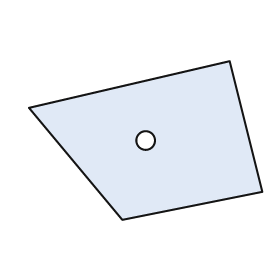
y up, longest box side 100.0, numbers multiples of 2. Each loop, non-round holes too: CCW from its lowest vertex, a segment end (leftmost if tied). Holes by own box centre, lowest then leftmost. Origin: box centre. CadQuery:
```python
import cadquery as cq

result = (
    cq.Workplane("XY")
    .moveTo(-10.0, -34.0)
    .lineTo(50.0, -22.0)
    .lineTo(36.0, 34.0)
    .lineTo(-50.0, 14.0)
    .close()
    .moveTo(0.0, 0.0)
    .circle(4.0)
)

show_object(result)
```